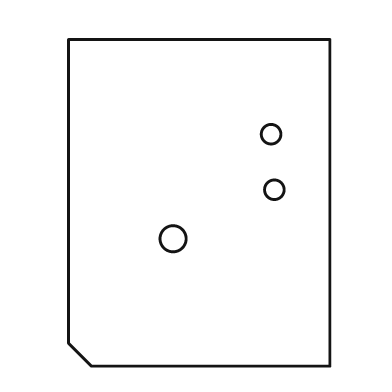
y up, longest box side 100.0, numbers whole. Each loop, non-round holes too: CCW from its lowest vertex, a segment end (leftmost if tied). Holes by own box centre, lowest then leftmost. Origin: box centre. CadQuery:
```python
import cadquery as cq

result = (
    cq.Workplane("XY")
    .moveTo(-33.0, -50.0)
    .lineTo(40.0, -50.0)
    .lineTo(40.0, 50.0)
    .lineTo(-40.0, 50.0)
    .lineTo(-40.0, -43.0)
    .close()
    .moveTo(-8.0, -11.0)
    .circle(4.0)
    .moveTo(23.0, 4.0)
    .circle(3.0)
    .moveTo(22.0, 21.0)
    .circle(3.0)
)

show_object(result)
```